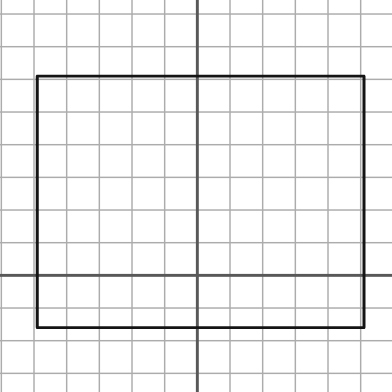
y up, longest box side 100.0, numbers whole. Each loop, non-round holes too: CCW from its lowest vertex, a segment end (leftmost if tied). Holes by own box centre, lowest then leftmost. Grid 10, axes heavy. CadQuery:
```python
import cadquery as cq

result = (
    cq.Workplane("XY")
    .moveTo(-49.0, -16.0)
    .lineTo(51.0, -16.0)
    .lineTo(51.0, 61.0)
    .lineTo(-49.0, 61.0)
    .close()
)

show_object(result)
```